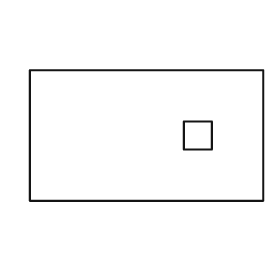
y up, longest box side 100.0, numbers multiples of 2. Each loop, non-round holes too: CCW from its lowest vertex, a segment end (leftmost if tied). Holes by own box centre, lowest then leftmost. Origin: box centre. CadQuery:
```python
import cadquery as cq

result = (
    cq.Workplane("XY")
    .moveTo(-50.0, -28.0)
    .lineTo(50.0, -28.0)
    .lineTo(50.0, 28.0)
    .lineTo(-50.0, 28.0)
    .close()
    .moveTo(16.0, -6.0)
    .lineTo(28.0, -6.0)
    .lineTo(28.0, 6.0)
    .lineTo(16.0, 6.0)
    .close()
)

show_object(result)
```